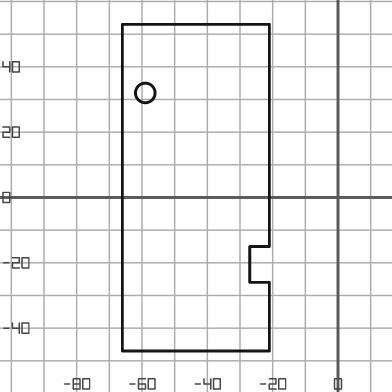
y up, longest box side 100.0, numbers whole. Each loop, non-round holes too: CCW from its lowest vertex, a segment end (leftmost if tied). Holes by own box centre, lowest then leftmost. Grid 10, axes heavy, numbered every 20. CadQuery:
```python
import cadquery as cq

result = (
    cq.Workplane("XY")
    .moveTo(-66.0, -47.0)
    .lineTo(-21.0, -47.0)
    .lineTo(-21.0, -26.0)
    .lineTo(-27.0, -26.0)
    .lineTo(-27.0, -15.0)
    .lineTo(-21.0, -15.0)
    .lineTo(-21.0, 53.0)
    .lineTo(-66.0, 53.0)
    .close()
    .moveTo(-59.0, 32.0)
    .circle(3.0)
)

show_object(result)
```